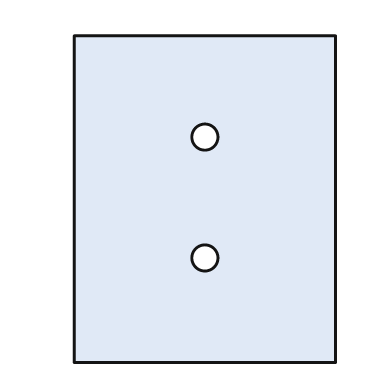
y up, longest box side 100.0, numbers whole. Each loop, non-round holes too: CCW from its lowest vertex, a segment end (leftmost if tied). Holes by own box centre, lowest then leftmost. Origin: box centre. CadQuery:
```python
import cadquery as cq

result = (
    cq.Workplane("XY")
    .moveTo(-40.0, -50.0)
    .lineTo(40.0, -50.0)
    .lineTo(40.0, 50.0)
    .lineTo(-40.0, 50.0)
    .close()
    .moveTo(0.0, -18.0)
    .circle(4.0)
    .moveTo(0.0, 19.0)
    .circle(4.0)
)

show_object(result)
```